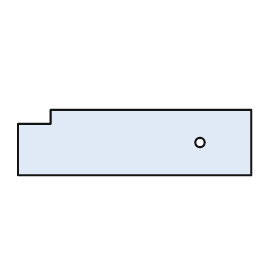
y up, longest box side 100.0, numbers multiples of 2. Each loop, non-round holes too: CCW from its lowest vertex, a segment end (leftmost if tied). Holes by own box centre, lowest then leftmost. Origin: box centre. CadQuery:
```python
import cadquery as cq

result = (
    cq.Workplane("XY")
    .moveTo(-50.0, -14.0)
    .lineTo(50.0, -14.0)
    .lineTo(50.0, 14.0)
    .lineTo(-36.0, 14.0)
    .lineTo(-36.0, 8.0)
    .lineTo(-50.0, 8.0)
    .close()
    .moveTo(28.0, 0.0)
    .circle(2.0)
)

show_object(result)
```